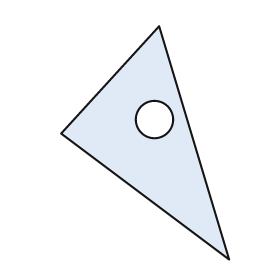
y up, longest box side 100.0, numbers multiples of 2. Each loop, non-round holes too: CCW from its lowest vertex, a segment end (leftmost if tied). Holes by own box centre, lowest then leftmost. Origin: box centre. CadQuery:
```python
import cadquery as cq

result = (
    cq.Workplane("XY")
    .moveTo(36.0, -50.0)
    .lineTo(6.0, 50.0)
    .lineTo(-36.0, 4.0)
    .close()
    .moveTo(4.0, 10.0)
    .circle(8.0)
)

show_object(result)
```